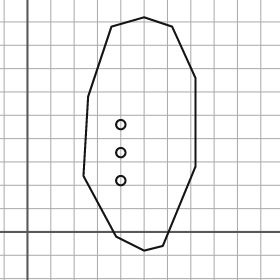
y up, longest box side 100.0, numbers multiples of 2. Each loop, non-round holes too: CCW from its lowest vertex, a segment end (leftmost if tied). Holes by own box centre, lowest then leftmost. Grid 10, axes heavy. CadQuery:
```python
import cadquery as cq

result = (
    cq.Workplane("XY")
    .moveTo(50.0, -8.0)
    .lineTo(58.0, -6.0)
    .lineTo(72.0, 28.0)
    .lineTo(72.0, 66.0)
    .lineTo(62.0, 88.0)
    .lineTo(50.0, 92.0)
    .lineTo(36.0, 88.0)
    .lineTo(26.0, 58.0)
    .lineTo(24.0, 24.0)
    .lineTo(38.0, -2.0)
    .close()
    .moveTo(40.0, 22.0)
    .circle(2.0)
    .moveTo(40.0, 34.0)
    .circle(2.0)
    .moveTo(40.0, 46.0)
    .circle(2.0)
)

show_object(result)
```